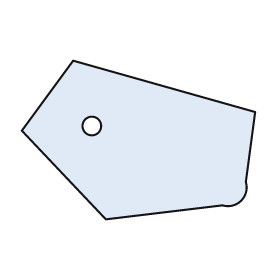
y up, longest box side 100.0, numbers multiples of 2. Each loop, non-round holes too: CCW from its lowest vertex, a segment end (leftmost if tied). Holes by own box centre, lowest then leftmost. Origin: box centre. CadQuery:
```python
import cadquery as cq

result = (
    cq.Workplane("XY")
    .moveTo(-14.0, -34.0)
    .lineTo(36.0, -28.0)
    .threePointArc((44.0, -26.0), (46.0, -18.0))
    .lineTo(50.0, 12.0)
    .lineTo(-28.0, 34.0)
    .lineTo(-50.0, 4.0)
    .close()
    .moveTo(-20.0, 6.0)
    .circle(4.0)
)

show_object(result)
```